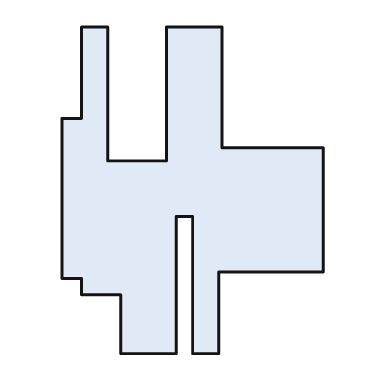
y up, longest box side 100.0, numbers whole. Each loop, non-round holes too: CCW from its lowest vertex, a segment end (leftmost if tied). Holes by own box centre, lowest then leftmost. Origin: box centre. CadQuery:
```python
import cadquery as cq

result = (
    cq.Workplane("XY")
    .moveTo(-22.0, -50.0)
    .lineTo(-5.0, -50.0)
    .lineTo(-5.0, -8.0)
    .lineTo(0.0, -8.0)
    .lineTo(0.0, -50.0)
    .lineTo(8.0, -50.0)
    .lineTo(8.0, -25.0)
    .lineTo(40.0, -25.0)
    .lineTo(40.0, 13.0)
    .lineTo(9.0, 13.0)
    .lineTo(9.0, 50.0)
    .lineTo(-8.0, 50.0)
    .lineTo(-8.0, 9.0)
    .lineTo(-26.0, 9.0)
    .lineTo(-26.0, 50.0)
    .lineTo(-34.0, 50.0)
    .lineTo(-34.0, 22.0)
    .lineTo(-40.0, 22.0)
    .lineTo(-40.0, -27.0)
    .lineTo(-34.0, -27.0)
    .lineTo(-34.0, -32.0)
    .lineTo(-22.0, -32.0)
    .close()
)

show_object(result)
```